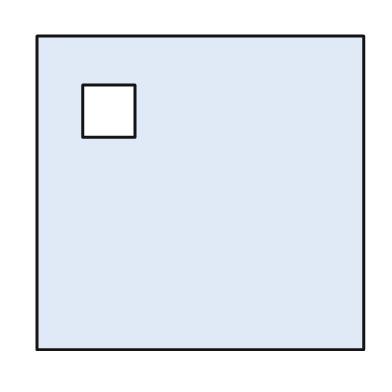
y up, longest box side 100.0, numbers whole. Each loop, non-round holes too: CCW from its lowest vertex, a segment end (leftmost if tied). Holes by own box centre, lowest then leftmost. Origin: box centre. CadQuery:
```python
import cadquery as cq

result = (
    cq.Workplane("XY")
    .moveTo(-50.0, -48.0)
    .lineTo(50.0, -48.0)
    .lineTo(50.0, 48.0)
    .lineTo(-50.0, 48.0)
    .close()
    .moveTo(-36.0, 17.0)
    .lineTo(-20.0, 17.0)
    .lineTo(-20.0, 33.0)
    .lineTo(-36.0, 33.0)
    .close()
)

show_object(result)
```